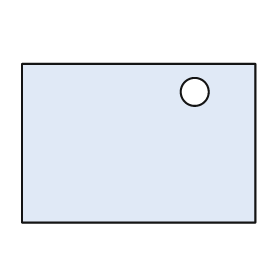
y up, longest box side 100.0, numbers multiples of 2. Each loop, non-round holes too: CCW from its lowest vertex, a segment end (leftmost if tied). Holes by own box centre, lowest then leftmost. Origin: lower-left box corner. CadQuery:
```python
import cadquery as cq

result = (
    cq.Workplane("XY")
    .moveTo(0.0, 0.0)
    .lineTo(100.0, 0.0)
    .lineTo(100.0, 68.0)
    .lineTo(0.0, 68.0)
    .close()
    .moveTo(74.0, 56.0)
    .circle(6.0)
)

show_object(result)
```